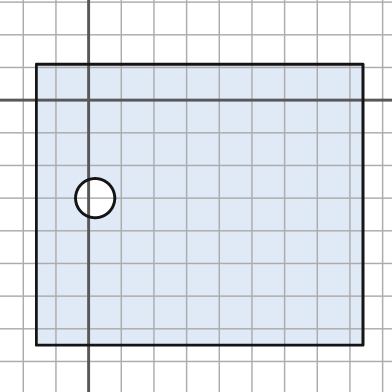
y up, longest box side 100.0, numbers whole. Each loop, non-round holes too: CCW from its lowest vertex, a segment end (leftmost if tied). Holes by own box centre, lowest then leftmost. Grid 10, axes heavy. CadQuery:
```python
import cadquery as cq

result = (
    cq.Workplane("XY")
    .moveTo(-16.0, -75.0)
    .lineTo(84.0, -75.0)
    .lineTo(84.0, 11.0)
    .lineTo(-16.0, 11.0)
    .close()
    .moveTo(2.0, -30.0)
    .circle(6.0)
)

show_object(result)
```